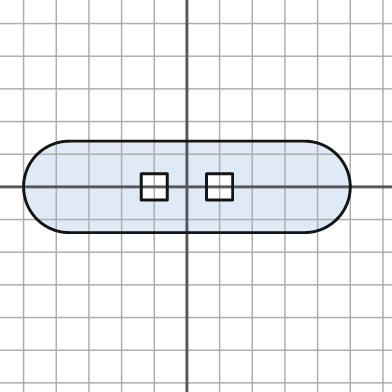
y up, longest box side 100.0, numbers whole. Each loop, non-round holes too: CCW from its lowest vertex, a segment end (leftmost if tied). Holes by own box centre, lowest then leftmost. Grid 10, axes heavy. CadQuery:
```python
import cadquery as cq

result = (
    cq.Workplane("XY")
    .moveTo(-36.0, -14.0)
    .lineTo(36.0, -14.0)
    .threePointArc((50.0, 0.0), (36.0, 14.0))
    .lineTo(-36.0, 14.0)
    .threePointArc((-50.0, 0.0), (-36.0, -14.0))
    .close()
    .moveTo(-14.0, -4.0)
    .lineTo(-6.0, -4.0)
    .lineTo(-6.0, 4.0)
    .lineTo(-14.0, 4.0)
    .close()
    .moveTo(6.0, -4.0)
    .lineTo(14.0, -4.0)
    .lineTo(14.0, 4.0)
    .lineTo(6.0, 4.0)
    .close()
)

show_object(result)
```